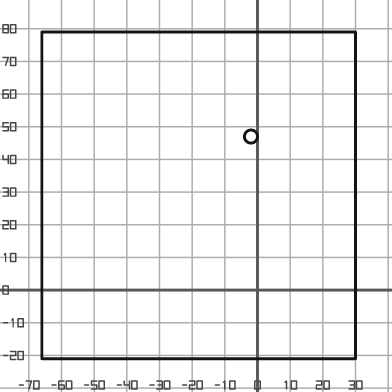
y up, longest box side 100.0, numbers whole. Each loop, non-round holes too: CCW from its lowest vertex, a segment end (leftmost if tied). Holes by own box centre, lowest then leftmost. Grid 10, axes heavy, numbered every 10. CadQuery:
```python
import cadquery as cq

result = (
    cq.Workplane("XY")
    .moveTo(-66.0, -21.0)
    .lineTo(30.0, -21.0)
    .lineTo(30.0, 79.0)
    .lineTo(-66.0, 79.0)
    .close()
    .moveTo(-2.0, 47.0)
    .circle(2.0)
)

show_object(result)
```